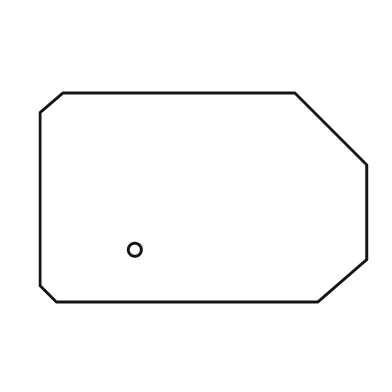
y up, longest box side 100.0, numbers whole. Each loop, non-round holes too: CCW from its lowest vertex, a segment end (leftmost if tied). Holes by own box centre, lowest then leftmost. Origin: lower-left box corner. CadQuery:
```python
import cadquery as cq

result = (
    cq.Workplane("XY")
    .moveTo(5.0, 0.0)
    .lineTo(85.0, 0.0)
    .lineTo(100.0, 13.0)
    .lineTo(100.0, 42.0)
    .lineTo(78.0, 64.0)
    .lineTo(7.0, 64.0)
    .lineTo(0.0, 58.0)
    .lineTo(0.0, 5.0)
    .close()
    .moveTo(29.0, 16.0)
    .circle(2.0)
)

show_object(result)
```